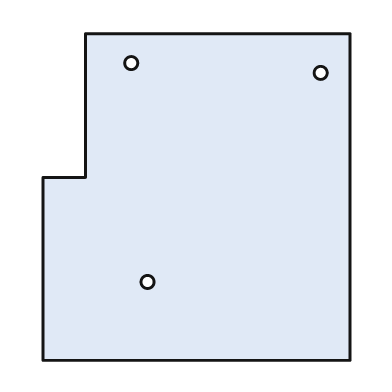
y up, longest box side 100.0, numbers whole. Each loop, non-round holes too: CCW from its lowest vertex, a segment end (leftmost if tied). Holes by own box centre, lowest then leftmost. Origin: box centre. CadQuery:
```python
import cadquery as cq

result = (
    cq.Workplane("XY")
    .moveTo(-47.0, -50.0)
    .lineTo(47.0, -50.0)
    .lineTo(47.0, 50.0)
    .lineTo(-34.0, 50.0)
    .lineTo(-34.0, 6.0)
    .lineTo(-47.0, 6.0)
    .close()
    .moveTo(-15.0, -26.0)
    .circle(2.0)
    .moveTo(38.0, 38.0)
    .circle(2.0)
    .moveTo(-20.0, 41.0)
    .circle(2.0)
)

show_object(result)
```